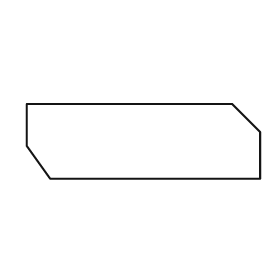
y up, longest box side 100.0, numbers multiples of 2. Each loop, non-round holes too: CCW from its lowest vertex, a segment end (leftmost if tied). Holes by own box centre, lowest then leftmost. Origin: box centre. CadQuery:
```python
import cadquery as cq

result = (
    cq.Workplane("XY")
    .moveTo(-40.0, -16.0)
    .lineTo(50.0, -16.0)
    .lineTo(50.0, 4.0)
    .lineTo(38.0, 16.0)
    .lineTo(-50.0, 16.0)
    .lineTo(-50.0, -2.0)
    .close()
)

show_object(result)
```